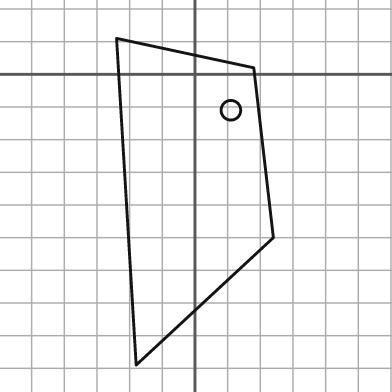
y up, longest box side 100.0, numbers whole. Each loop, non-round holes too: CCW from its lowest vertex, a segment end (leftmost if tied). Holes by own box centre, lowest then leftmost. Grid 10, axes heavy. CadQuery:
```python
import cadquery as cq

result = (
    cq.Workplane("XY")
    .moveTo(-18.0, -89.0)
    .lineTo(24.0, -50.0)
    .lineTo(18.0, 2.0)
    .lineTo(-24.0, 11.0)
    .close()
    .moveTo(11.0, -11.0)
    .circle(3.0)
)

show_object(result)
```